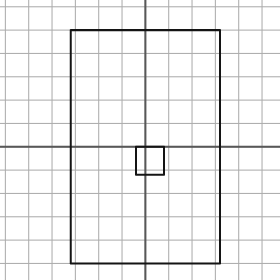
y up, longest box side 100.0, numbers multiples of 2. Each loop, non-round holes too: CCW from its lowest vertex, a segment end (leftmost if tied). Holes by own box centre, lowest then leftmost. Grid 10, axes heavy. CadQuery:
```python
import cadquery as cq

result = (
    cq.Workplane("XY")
    .moveTo(-32.0, -50.0)
    .lineTo(32.0, -50.0)
    .lineTo(32.0, 50.0)
    .lineTo(-32.0, 50.0)
    .close()
    .moveTo(-4.0, -12.0)
    .lineTo(8.0, -12.0)
    .lineTo(8.0, 0.0)
    .lineTo(-4.0, 0.0)
    .close()
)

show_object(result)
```